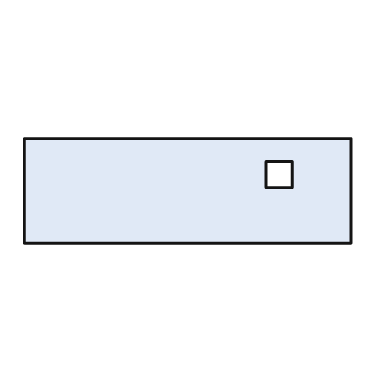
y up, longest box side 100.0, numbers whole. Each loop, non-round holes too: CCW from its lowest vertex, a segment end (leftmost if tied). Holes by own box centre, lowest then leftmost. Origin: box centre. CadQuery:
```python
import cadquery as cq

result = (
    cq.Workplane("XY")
    .moveTo(-50.0, -16.0)
    .lineTo(50.0, -16.0)
    .lineTo(50.0, 16.0)
    .lineTo(-50.0, 16.0)
    .close()
    .moveTo(24.0, 1.0)
    .lineTo(32.0, 1.0)
    .lineTo(32.0, 9.0)
    .lineTo(24.0, 9.0)
    .close()
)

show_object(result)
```